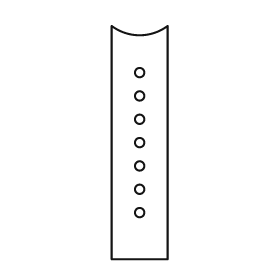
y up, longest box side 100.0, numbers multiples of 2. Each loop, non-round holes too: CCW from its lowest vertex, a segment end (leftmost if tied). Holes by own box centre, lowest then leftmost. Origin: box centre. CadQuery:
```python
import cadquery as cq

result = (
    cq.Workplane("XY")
    .moveTo(-12.0, -50.0)
    .lineTo(12.0, -50.0)
    .lineTo(12.0, 50.0)
    .threePointArc((0.0, 46.0), (-12.0, 50.0))
    .close()
    .moveTo(0.0, -30.0)
    .circle(2.0)
    .moveTo(0.0, -20.0)
    .circle(2.0)
    .moveTo(0.0, -10.0)
    .circle(2.0)
    .moveTo(0.0, 0.0)
    .circle(2.0)
    .moveTo(0.0, 10.0)
    .circle(2.0)
    .moveTo(0.0, 20.0)
    .circle(2.0)
    .moveTo(0.0, 30.0)
    .circle(2.0)
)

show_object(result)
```